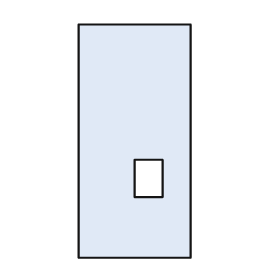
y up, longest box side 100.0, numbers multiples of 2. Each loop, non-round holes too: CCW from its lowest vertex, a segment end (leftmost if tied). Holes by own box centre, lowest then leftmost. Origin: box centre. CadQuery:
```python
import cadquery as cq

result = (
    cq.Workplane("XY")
    .moveTo(-24.0, -50.0)
    .lineTo(24.0, -50.0)
    .lineTo(24.0, 50.0)
    .lineTo(-24.0, 50.0)
    .close()
    .moveTo(0.0, -24.0)
    .lineTo(12.0, -24.0)
    .lineTo(12.0, -8.0)
    .lineTo(0.0, -8.0)
    .close()
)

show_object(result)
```